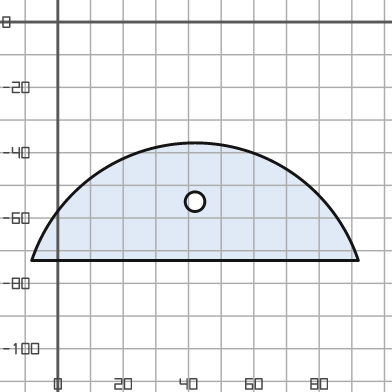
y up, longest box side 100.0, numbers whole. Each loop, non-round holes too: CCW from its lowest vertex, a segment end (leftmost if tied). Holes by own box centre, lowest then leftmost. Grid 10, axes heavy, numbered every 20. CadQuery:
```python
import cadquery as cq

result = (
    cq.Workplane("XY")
    .moveTo(-8.0, -73.0)
    .lineTo(92.0, -73.0)
    .threePointArc((42.0, -37.0), (-8.0, -73.0))
    .close()
    .moveTo(42.0, -55.0)
    .circle(3.0)
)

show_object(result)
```